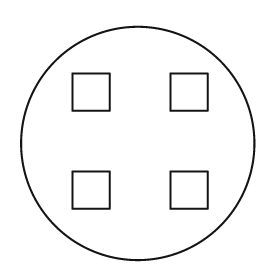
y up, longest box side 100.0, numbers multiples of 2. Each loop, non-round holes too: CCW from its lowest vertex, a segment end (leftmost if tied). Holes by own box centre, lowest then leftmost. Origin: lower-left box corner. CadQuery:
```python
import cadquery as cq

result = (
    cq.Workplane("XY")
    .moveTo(50.0, 50.0)
    .circle(50.0)
    .moveTo(22.0, 22.0)
    .lineTo(38.0, 22.0)
    .lineTo(38.0, 38.0)
    .lineTo(22.0, 38.0)
    .close()
    .moveTo(64.0, 22.0)
    .lineTo(80.0, 22.0)
    .lineTo(80.0, 38.0)
    .lineTo(64.0, 38.0)
    .close()
    .moveTo(22.0, 64.0)
    .lineTo(38.0, 64.0)
    .lineTo(38.0, 80.0)
    .lineTo(22.0, 80.0)
    .close()
    .moveTo(64.0, 64.0)
    .lineTo(80.0, 64.0)
    .lineTo(80.0, 80.0)
    .lineTo(64.0, 80.0)
    .close()
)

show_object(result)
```